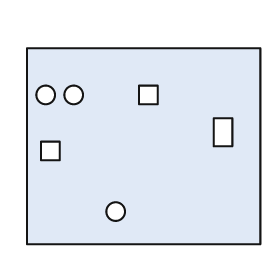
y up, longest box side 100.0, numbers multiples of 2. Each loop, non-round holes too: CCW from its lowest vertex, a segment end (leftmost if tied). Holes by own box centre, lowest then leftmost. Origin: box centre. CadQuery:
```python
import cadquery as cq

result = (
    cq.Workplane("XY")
    .moveTo(-50.0, -42.0)
    .lineTo(50.0, -42.0)
    .lineTo(50.0, 42.0)
    .lineTo(-50.0, 42.0)
    .close()
    .moveTo(-12.0, -28.0)
    .circle(4.0)
    .moveTo(-44.0, -6.0)
    .lineTo(-36.0, -6.0)
    .lineTo(-36.0, 2.0)
    .lineTo(-44.0, 2.0)
    .close()
    .moveTo(30.0, 0.0)
    .lineTo(38.0, 0.0)
    .lineTo(38.0, 12.0)
    .lineTo(30.0, 12.0)
    .close()
    .moveTo(-42.0, 22.0)
    .circle(4.0)
    .moveTo(-30.0, 22.0)
    .circle(4.0)
    .moveTo(-2.0, 18.0)
    .lineTo(6.0, 18.0)
    .lineTo(6.0, 26.0)
    .lineTo(-2.0, 26.0)
    .close()
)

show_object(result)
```